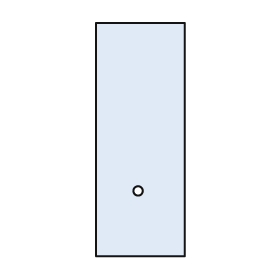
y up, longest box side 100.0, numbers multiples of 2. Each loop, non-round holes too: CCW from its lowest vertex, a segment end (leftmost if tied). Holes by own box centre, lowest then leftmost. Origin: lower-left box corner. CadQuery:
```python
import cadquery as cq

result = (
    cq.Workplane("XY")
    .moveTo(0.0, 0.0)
    .lineTo(38.0, 0.0)
    .lineTo(38.0, 100.0)
    .lineTo(0.0, 100.0)
    .close()
    .moveTo(18.0, 28.0)
    .circle(2.0)
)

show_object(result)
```